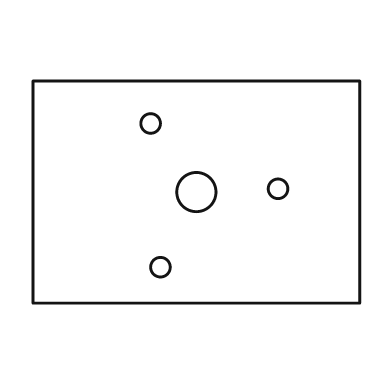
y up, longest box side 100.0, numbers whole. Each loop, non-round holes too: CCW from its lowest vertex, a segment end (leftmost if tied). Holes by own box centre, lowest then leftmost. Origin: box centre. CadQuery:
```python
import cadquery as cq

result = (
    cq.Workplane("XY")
    .moveTo(-50.0, -34.0)
    .lineTo(50.0, -34.0)
    .lineTo(50.0, 34.0)
    .lineTo(-50.0, 34.0)
    .close()
    .moveTo(-11.0, -23.0)
    .circle(3.0)
    .moveTo(0.0, 0.0)
    .circle(6.0)
    .moveTo(25.0, 1.0)
    .circle(3.0)
    .moveTo(-14.0, 21.0)
    .circle(3.0)
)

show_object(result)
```